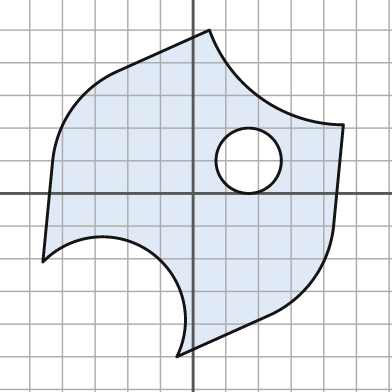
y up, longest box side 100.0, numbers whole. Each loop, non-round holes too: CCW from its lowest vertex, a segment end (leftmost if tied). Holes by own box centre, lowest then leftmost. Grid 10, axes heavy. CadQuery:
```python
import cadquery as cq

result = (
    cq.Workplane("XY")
    .moveTo(-5.0, -50.0)
    .lineTo(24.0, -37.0)
    .threePointArc((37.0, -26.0), (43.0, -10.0))
    .lineTo(46.0, 21.0)
    .threePointArc((21.0, 29.0), (5.0, 50.0))
    .lineTo(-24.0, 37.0)
    .threePointArc((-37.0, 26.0), (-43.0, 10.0))
    .lineTo(-46.0, -21.0)
    .threePointArc((-13.0, -18.0), (-5.0, -50.0))
    .close()
    .moveTo(17.0, 10.0)
    .circle(10.0)
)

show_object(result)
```